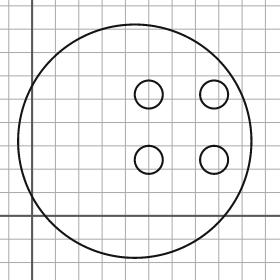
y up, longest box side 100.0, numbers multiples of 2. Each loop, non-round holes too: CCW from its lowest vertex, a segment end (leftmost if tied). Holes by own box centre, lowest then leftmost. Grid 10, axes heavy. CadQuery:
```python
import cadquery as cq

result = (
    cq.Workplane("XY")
    .moveTo(44.0, 32.0)
    .circle(50.0)
    .moveTo(50.0, 24.0)
    .circle(6.0)
    .moveTo(78.0, 24.0)
    .circle(6.0)
    .moveTo(50.0, 52.0)
    .circle(6.0)
    .moveTo(78.0, 52.0)
    .circle(6.0)
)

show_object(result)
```